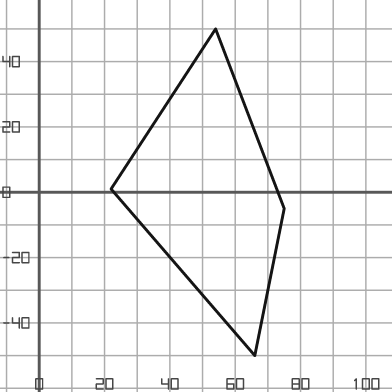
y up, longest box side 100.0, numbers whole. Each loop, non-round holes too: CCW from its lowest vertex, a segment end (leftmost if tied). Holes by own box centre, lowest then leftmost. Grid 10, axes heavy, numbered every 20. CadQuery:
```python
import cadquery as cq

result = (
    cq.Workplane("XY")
    .moveTo(66.0, -50.0)
    .lineTo(75.0, -5.0)
    .lineTo(54.0, 50.0)
    .lineTo(22.0, 1.0)
    .close()
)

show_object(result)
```